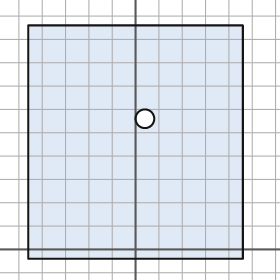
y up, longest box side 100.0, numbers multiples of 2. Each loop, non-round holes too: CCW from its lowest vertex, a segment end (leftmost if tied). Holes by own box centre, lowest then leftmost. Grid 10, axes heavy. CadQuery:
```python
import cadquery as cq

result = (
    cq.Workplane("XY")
    .moveTo(-46.0, -4.0)
    .lineTo(46.0, -4.0)
    .lineTo(46.0, 96.0)
    .lineTo(-46.0, 96.0)
    .close()
    .moveTo(4.0, 56.0)
    .circle(4.0)
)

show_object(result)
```